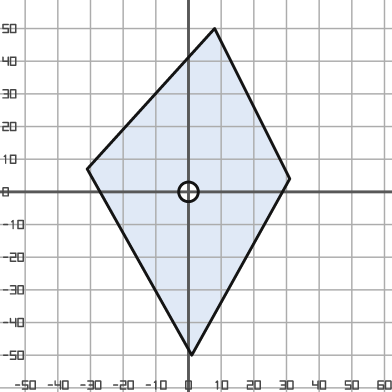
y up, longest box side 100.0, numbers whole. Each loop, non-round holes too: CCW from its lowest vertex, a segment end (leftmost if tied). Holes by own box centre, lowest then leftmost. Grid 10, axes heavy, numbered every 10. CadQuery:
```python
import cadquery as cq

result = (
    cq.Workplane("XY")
    .moveTo(1.0, -50.0)
    .lineTo(31.0, 4.0)
    .lineTo(8.0, 50.0)
    .lineTo(-31.0, 7.0)
    .close()
    .moveTo(0.0, 0.0)
    .circle(3.0)
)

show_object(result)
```